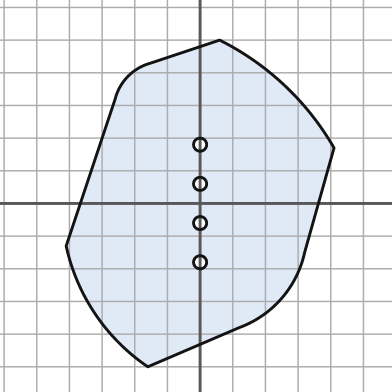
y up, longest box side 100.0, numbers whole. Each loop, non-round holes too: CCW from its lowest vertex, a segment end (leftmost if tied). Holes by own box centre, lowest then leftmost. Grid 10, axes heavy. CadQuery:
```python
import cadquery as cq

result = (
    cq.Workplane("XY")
    .moveTo(-16.0, -50.0)
    .lineTo(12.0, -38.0)
    .threePointArc((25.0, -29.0), (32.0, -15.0))
    .lineTo(41.0, 17.0)
    .threePointArc((26.0, 36.0), (6.0, 50.0))
    .lineTo(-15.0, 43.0)
    .threePointArc((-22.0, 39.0), (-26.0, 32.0))
    .lineTo(-41.0, -13.0)
    .threePointArc((-32.0, -34.0), (-16.0, -50.0))
    .close()
    .moveTo(0.0, -18.0)
    .circle(2.0)
    .moveTo(0.0, -6.0)
    .circle(2.0)
    .moveTo(0.0, 6.0)
    .circle(2.0)
    .moveTo(0.0, 18.0)
    .circle(2.0)
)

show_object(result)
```